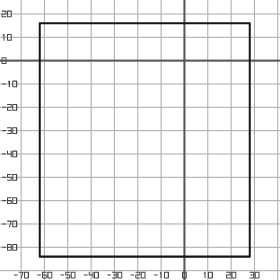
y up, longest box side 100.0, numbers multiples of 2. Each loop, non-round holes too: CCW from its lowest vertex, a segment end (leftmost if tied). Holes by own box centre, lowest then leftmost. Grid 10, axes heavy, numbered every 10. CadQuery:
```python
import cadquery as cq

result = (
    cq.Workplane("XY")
    .moveTo(-62.0, -84.0)
    .lineTo(28.0, -84.0)
    .lineTo(28.0, 16.0)
    .lineTo(-62.0, 16.0)
    .close()
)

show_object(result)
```